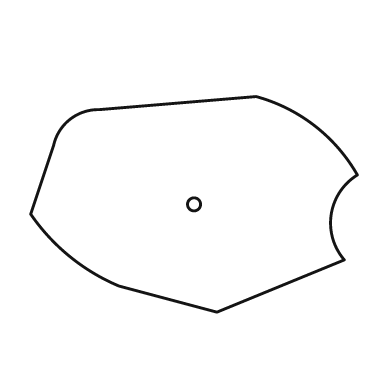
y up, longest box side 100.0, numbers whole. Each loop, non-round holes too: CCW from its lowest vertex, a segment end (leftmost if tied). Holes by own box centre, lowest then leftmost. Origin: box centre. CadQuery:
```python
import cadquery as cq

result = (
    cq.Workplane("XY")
    .moveTo(7.0, -33.0)
    .lineTo(46.0, -17.0)
    .threePointArc((42.0, -3.0), (50.0, 9.0))
    .threePointArc((37.0, 24.0), (19.0, 33.0))
    .lineTo(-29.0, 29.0)
    .threePointArc((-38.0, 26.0), (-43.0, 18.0))
    .lineTo(-50.0, -3.0)
    .threePointArc((-38.0, -16.0), (-23.0, -25.0))
    .close()
    .moveTo(0.0, 0.0)
    .circle(2.0)
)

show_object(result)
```